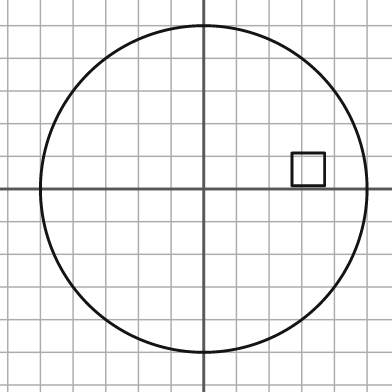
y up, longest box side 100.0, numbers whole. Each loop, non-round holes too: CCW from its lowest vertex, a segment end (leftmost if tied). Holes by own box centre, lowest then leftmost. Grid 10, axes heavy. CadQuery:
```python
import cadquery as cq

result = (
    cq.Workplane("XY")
    .moveTo(0.0, 0.0)
    .circle(50.0)
    .moveTo(27.0, 1.0)
    .lineTo(37.0, 1.0)
    .lineTo(37.0, 11.0)
    .lineTo(27.0, 11.0)
    .close()
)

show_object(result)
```